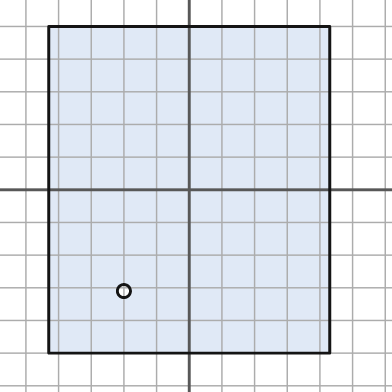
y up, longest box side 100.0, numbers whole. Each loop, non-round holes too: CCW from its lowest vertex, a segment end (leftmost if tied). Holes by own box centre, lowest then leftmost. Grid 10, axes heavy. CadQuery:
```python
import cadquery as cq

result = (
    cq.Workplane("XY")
    .moveTo(-43.0, -50.0)
    .lineTo(43.0, -50.0)
    .lineTo(43.0, 50.0)
    .lineTo(-43.0, 50.0)
    .close()
    .moveTo(-20.0, -31.0)
    .circle(2.0)
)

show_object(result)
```